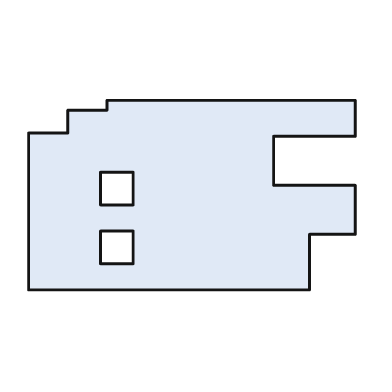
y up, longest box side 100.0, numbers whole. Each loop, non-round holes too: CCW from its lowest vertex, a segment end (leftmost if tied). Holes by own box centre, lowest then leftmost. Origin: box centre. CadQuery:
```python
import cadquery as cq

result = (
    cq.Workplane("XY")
    .moveTo(-50.0, -29.0)
    .lineTo(36.0, -29.0)
    .lineTo(36.0, -12.0)
    .lineTo(50.0, -12.0)
    .lineTo(50.0, 3.0)
    .lineTo(25.0, 3.0)
    .lineTo(25.0, 18.0)
    .lineTo(50.0, 18.0)
    .lineTo(50.0, 29.0)
    .lineTo(-26.0, 29.0)
    .lineTo(-26.0, 26.0)
    .lineTo(-38.0, 26.0)
    .lineTo(-38.0, 19.0)
    .lineTo(-50.0, 19.0)
    .close()
    .moveTo(-28.0, -21.0)
    .lineTo(-18.0, -21.0)
    .lineTo(-18.0, -11.0)
    .lineTo(-28.0, -11.0)
    .close()
    .moveTo(-28.0, -3.0)
    .lineTo(-18.0, -3.0)
    .lineTo(-18.0, 7.0)
    .lineTo(-28.0, 7.0)
    .close()
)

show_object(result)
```